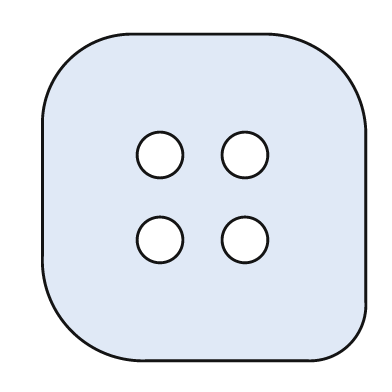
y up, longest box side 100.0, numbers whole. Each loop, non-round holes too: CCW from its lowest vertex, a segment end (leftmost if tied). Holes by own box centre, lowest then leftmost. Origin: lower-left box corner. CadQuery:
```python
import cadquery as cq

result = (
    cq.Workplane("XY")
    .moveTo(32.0, 0.0)
    .lineTo(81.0, 0.0)
    .threePointArc((94.0, 5.0), (99.0, 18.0))
    .lineTo(99.0, 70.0)
    .threePointArc((90.0, 91.0), (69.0, 100.0))
    .lineTo(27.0, 100.0)
    .threePointArc((8.0, 92.0), (0.0, 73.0))
    .lineTo(0.0, 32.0)
    .threePointArc((9.0, 9.0), (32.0, 0.0))
    .close()
    .moveTo(36.0, 37.0)
    .circle(7.0)
    .moveTo(62.0, 37.0)
    .circle(7.0)
    .moveTo(36.0, 63.0)
    .circle(7.0)
    .moveTo(62.0, 63.0)
    .circle(7.0)
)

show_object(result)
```